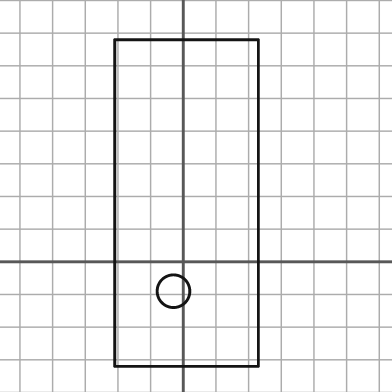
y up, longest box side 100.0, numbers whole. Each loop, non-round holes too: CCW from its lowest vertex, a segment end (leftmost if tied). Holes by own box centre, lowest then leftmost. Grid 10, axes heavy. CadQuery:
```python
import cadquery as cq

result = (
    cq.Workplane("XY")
    .moveTo(-21.0, -32.0)
    .lineTo(23.0, -32.0)
    .lineTo(23.0, 68.0)
    .lineTo(-21.0, 68.0)
    .close()
    .moveTo(-3.0, -9.0)
    .circle(5.0)
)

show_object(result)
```